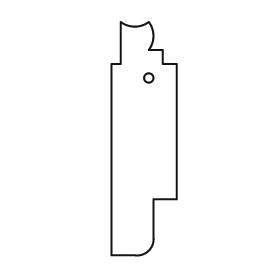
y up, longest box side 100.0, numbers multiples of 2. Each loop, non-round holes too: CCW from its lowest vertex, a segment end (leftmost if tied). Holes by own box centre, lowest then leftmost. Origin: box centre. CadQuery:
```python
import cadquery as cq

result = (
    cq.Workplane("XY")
    .moveTo(-14.0, -50.0)
    .lineTo(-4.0, -50.0)
    .threePointArc((2.0, -48.0), (4.0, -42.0))
    .lineTo(4.0, -26.0)
    .lineTo(14.0, -26.0)
    .lineTo(14.0, 32.0)
    .lineTo(8.0, 32.0)
    .lineTo(8.0, 38.0)
    .lineTo(2.0, 38.0)
    .threePointArc((4.0, 44.0), (2.0, 50.0))
    .threePointArc((-4.0, 48.0), (-10.0, 50.0))
    .lineTo(-10.0, 32.0)
    .lineTo(-14.0, 32.0)
    .close()
    .moveTo(2.0, 26.0)
    .circle(2.0)
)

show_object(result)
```